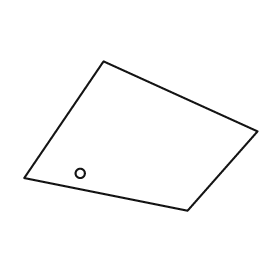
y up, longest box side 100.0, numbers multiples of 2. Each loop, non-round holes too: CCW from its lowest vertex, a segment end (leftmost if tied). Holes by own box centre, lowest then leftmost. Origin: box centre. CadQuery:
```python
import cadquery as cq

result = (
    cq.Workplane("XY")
    .moveTo(20.0, -32.0)
    .lineTo(50.0, 2.0)
    .lineTo(-16.0, 32.0)
    .lineTo(-50.0, -18.0)
    .close()
    .moveTo(-26.0, -16.0)
    .circle(2.0)
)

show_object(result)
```